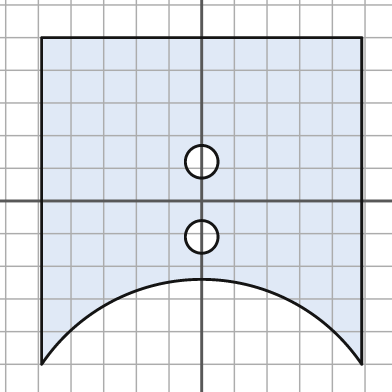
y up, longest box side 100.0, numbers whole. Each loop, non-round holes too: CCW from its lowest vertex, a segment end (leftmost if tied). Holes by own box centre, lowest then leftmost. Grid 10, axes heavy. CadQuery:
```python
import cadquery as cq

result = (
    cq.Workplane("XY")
    .moveTo(-49.0, -50.0)
    .threePointArc((0.0, -24.0), (49.0, -50.0))
    .lineTo(49.0, 50.0)
    .lineTo(-49.0, 50.0)
    .close()
    .moveTo(0.0, -11.0)
    .circle(5.0)
    .moveTo(0.0, 12.0)
    .circle(5.0)
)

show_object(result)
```